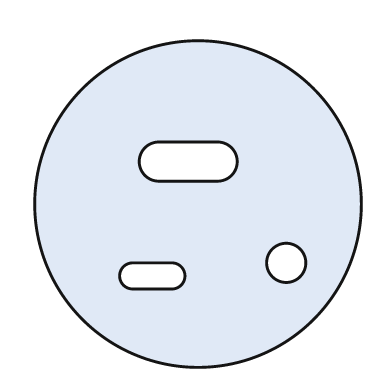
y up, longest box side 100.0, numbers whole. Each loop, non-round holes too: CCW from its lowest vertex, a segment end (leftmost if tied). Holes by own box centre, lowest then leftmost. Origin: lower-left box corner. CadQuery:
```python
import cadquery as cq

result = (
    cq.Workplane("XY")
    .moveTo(50.0, 50.0)
    .circle(50.0)
    .moveTo(30.0, 24.0)
    .lineTo(42.0, 24.0)
    .threePointArc((46.0, 28.0), (42.0, 32.0))
    .lineTo(30.0, 32.0)
    .threePointArc((26.0, 28.0), (30.0, 24.0))
    .close()
    .moveTo(77.0, 32.0)
    .circle(6.0)
    .moveTo(38.0, 57.0)
    .lineTo(56.0, 57.0)
    .threePointArc((62.0, 63.0), (56.0, 69.0))
    .lineTo(38.0, 69.0)
    .threePointArc((32.0, 63.0), (38.0, 57.0))
    .close()
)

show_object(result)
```